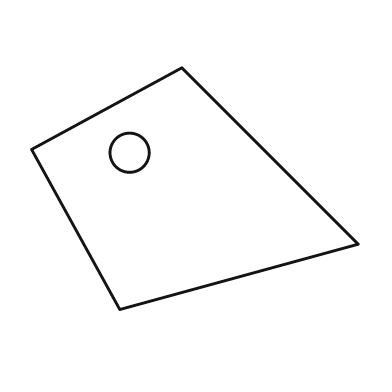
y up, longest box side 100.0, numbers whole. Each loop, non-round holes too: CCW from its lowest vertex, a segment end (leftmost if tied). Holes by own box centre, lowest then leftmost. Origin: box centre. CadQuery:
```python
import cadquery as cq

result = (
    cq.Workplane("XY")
    .moveTo(-23.0, -37.0)
    .lineTo(50.0, -17.0)
    .lineTo(-4.0, 37.0)
    .lineTo(-50.0, 12.0)
    .close()
    .moveTo(-20.0, 11.0)
    .circle(6.0)
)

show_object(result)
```